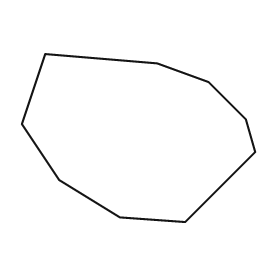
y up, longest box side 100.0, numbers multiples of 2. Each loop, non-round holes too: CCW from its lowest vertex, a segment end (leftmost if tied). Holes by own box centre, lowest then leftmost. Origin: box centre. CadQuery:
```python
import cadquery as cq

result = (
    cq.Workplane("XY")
    .moveTo(20.0, -36.0)
    .lineTo(50.0, -6.0)
    .lineTo(46.0, 8.0)
    .lineTo(30.0, 24.0)
    .lineTo(8.0, 32.0)
    .lineTo(-40.0, 36.0)
    .lineTo(-50.0, 6.0)
    .lineTo(-34.0, -18.0)
    .lineTo(-8.0, -34.0)
    .close()
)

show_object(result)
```